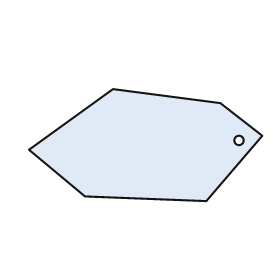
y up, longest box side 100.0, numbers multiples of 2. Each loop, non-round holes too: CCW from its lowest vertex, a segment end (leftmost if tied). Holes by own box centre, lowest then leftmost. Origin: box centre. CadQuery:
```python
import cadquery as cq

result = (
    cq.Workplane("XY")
    .moveTo(26.0, -24.0)
    .lineTo(50.0, 4.0)
    .lineTo(32.0, 18.0)
    .lineTo(-14.0, 24.0)
    .lineTo(-50.0, -2.0)
    .lineTo(-26.0, -22.0)
    .close()
    .moveTo(40.0, 2.0)
    .circle(2.0)
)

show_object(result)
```